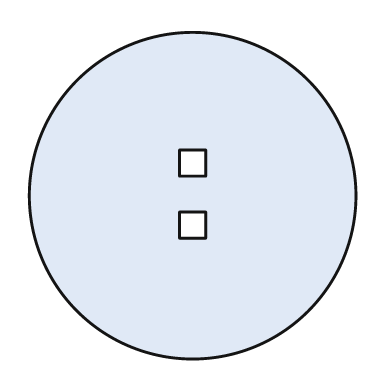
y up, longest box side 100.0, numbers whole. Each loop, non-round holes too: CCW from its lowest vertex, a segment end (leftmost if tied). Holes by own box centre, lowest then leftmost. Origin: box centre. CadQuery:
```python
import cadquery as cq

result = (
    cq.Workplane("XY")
    .moveTo(0.0, 0.0)
    .circle(50.0)
    .moveTo(-4.0, -13.0)
    .lineTo(4.0, -13.0)
    .lineTo(4.0, -5.0)
    .lineTo(-4.0, -5.0)
    .close()
    .moveTo(-4.0, 6.0)
    .lineTo(4.0, 6.0)
    .lineTo(4.0, 14.0)
    .lineTo(-4.0, 14.0)
    .close()
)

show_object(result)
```